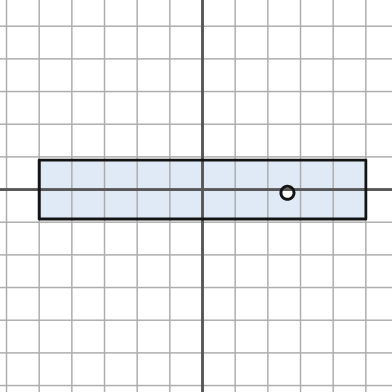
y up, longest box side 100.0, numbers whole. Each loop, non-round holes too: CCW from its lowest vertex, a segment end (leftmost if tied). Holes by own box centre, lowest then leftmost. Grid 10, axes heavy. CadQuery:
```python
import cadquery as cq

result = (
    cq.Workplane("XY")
    .moveTo(-50.0, -9.0)
    .lineTo(50.0, -9.0)
    .lineTo(50.0, 9.0)
    .lineTo(-50.0, 9.0)
    .close()
    .moveTo(26.0, -1.0)
    .circle(2.0)
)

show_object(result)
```